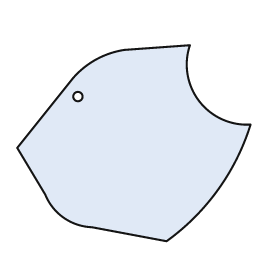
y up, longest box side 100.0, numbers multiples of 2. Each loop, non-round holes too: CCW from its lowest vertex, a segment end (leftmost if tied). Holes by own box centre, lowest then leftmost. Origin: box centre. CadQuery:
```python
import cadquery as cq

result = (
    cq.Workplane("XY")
    .moveTo(14.0, -42.0)
    .threePointArc((36.0, -20.0), (50.0, 8.0))
    .threePointArc((28.0, 18.0), (24.0, 42.0))
    .lineTo(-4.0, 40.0)
    .threePointArc((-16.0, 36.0), (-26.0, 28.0))
    .lineTo(-50.0, -2.0)
    .lineTo(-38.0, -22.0)
    .threePointArc((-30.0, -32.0), (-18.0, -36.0))
    .close()
    .moveTo(-24.0, 20.0)
    .circle(2.0)
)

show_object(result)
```